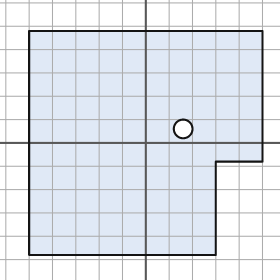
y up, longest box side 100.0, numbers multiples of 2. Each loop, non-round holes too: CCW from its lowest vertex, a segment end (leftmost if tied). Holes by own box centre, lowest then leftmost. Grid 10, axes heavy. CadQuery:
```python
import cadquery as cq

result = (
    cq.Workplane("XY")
    .moveTo(-50.0, -48.0)
    .lineTo(30.0, -48.0)
    .lineTo(30.0, -8.0)
    .lineTo(50.0, -8.0)
    .lineTo(50.0, 48.0)
    .lineTo(-50.0, 48.0)
    .close()
    .moveTo(16.0, 6.0)
    .circle(4.0)
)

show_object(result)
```